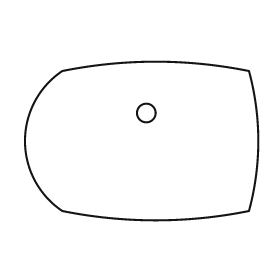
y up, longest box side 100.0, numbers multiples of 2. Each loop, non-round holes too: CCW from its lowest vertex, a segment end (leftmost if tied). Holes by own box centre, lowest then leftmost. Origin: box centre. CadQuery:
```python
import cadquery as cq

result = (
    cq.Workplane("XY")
    .moveTo(-34.0, -30.0)
    .threePointArc((6.0, -34.0), (46.0, -30.0))
    .threePointArc((50.0, 0.0), (46.0, 30.0))
    .threePointArc((6.0, 34.0), (-34.0, 30.0))
    .threePointArc((-50.0, 0.0), (-34.0, -30.0))
    .close()
    .moveTo(2.0, 12.0)
    .circle(4.0)
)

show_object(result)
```